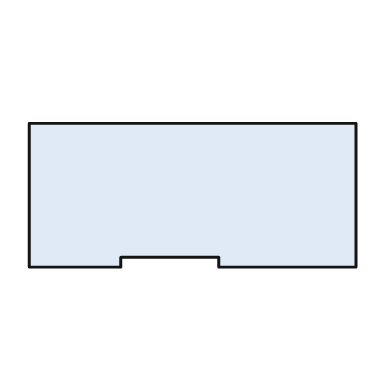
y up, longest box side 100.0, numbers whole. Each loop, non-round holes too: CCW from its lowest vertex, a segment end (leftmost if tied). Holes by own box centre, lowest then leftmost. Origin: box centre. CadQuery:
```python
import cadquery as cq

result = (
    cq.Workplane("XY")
    .moveTo(-50.0, -22.0)
    .lineTo(-22.0, -22.0)
    .lineTo(-22.0, -19.0)
    .lineTo(8.0, -19.0)
    .lineTo(8.0, -22.0)
    .lineTo(50.0, -22.0)
    .lineTo(50.0, 22.0)
    .lineTo(-50.0, 22.0)
    .close()
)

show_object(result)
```